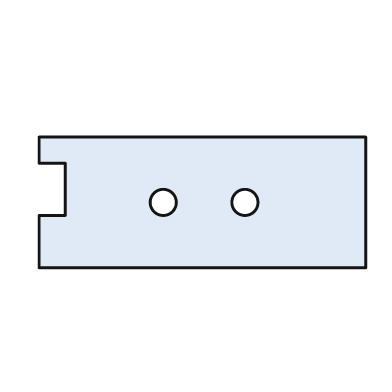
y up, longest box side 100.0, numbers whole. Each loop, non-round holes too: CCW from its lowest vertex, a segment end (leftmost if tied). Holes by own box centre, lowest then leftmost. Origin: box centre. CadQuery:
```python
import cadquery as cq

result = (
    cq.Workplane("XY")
    .moveTo(-50.0, -20.0)
    .lineTo(50.0, -20.0)
    .lineTo(50.0, 20.0)
    .lineTo(-50.0, 20.0)
    .lineTo(-50.0, 12.0)
    .lineTo(-42.0, 12.0)
    .lineTo(-42.0, -4.0)
    .lineTo(-50.0, -4.0)
    .close()
    .moveTo(-12.0, 0.0)
    .circle(4.0)
    .moveTo(13.0, 0.0)
    .circle(4.0)
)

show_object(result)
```